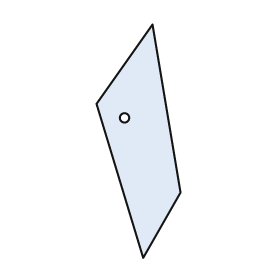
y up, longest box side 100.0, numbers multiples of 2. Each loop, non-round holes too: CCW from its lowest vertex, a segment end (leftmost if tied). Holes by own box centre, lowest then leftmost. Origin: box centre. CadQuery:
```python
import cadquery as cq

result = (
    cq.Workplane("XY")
    .moveTo(2.0, -50.0)
    .lineTo(18.0, -22.0)
    .lineTo(6.0, 50.0)
    .lineTo(-18.0, 16.0)
    .close()
    .moveTo(-6.0, 10.0)
    .circle(2.0)
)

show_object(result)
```